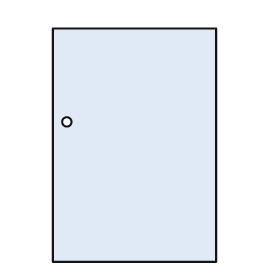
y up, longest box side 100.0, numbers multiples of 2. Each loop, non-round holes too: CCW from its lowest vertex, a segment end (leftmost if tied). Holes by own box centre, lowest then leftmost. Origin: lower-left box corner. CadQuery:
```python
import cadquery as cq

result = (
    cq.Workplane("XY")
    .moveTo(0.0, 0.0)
    .lineTo(70.0, 0.0)
    .lineTo(70.0, 100.0)
    .lineTo(0.0, 100.0)
    .close()
    .moveTo(6.0, 60.0)
    .circle(2.0)
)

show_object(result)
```